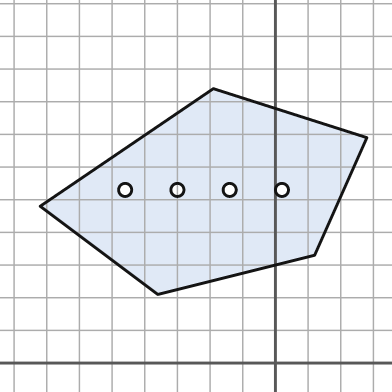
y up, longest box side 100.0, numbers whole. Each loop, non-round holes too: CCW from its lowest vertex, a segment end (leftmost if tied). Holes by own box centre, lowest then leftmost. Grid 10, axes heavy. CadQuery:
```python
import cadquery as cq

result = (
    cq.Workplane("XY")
    .moveTo(-36.0, 21.0)
    .lineTo(12.0, 33.0)
    .lineTo(28.0, 69.0)
    .lineTo(-19.0, 84.0)
    .lineTo(-72.0, 48.0)
    .close()
    .moveTo(-46.0, 53.0)
    .circle(2.0)
    .moveTo(-30.0, 53.0)
    .circle(2.0)
    .moveTo(-14.0, 53.0)
    .circle(2.0)
    .moveTo(2.0, 53.0)
    .circle(2.0)
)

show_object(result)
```